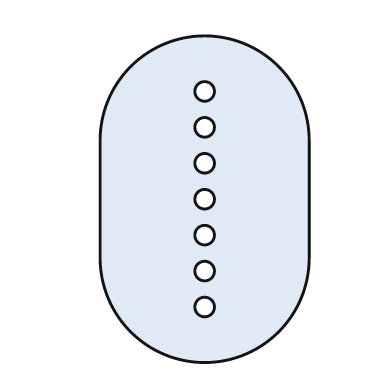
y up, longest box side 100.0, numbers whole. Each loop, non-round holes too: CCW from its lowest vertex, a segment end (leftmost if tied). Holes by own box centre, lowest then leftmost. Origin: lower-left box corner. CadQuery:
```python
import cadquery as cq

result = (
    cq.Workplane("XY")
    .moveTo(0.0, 32.0)
    .threePointArc((32.0, 0.0), (64.0, 32.0))
    .lineTo(64.0, 68.0)
    .threePointArc((32.0, 100.0), (0.0, 68.0))
    .close()
    .moveTo(32.0, 17.0)
    .circle(3.0)
    .moveTo(32.0, 28.0)
    .circle(3.0)
    .moveTo(32.0, 39.0)
    .circle(3.0)
    .moveTo(32.0, 50.0)
    .circle(3.0)
    .moveTo(32.0, 61.0)
    .circle(3.0)
    .moveTo(32.0, 72.0)
    .circle(3.0)
    .moveTo(32.0, 83.0)
    .circle(3.0)
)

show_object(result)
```